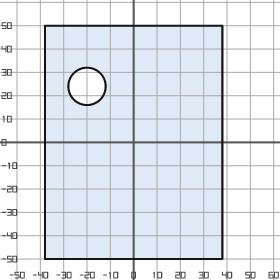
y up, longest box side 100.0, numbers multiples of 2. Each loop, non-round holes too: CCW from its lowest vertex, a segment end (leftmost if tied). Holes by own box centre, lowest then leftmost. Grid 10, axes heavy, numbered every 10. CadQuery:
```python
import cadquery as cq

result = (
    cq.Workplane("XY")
    .moveTo(-38.0, -50.0)
    .lineTo(38.0, -50.0)
    .lineTo(38.0, 50.0)
    .lineTo(-38.0, 50.0)
    .close()
    .moveTo(-20.0, 24.0)
    .circle(8.0)
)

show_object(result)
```